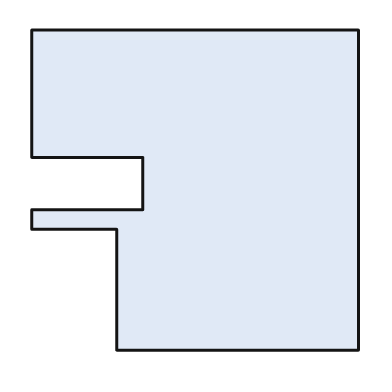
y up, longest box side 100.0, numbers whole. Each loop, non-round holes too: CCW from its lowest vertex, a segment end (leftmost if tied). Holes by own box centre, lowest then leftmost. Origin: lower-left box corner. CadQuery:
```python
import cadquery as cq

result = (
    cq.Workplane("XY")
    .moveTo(26.0, 0.0)
    .lineTo(100.0, 0.0)
    .lineTo(100.0, 98.0)
    .lineTo(0.0, 98.0)
    .lineTo(0.0, 59.0)
    .lineTo(34.0, 59.0)
    .lineTo(34.0, 43.0)
    .lineTo(0.0, 43.0)
    .lineTo(0.0, 37.0)
    .lineTo(26.0, 37.0)
    .close()
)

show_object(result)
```